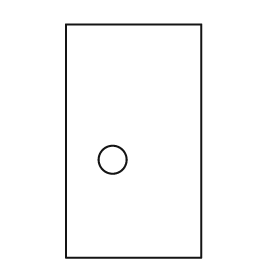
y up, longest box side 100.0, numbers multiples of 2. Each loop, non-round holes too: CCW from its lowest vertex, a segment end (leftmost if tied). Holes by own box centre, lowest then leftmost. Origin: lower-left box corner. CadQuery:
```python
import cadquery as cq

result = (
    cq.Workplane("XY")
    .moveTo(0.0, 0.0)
    .lineTo(58.0, 0.0)
    .lineTo(58.0, 100.0)
    .lineTo(0.0, 100.0)
    .close()
    .moveTo(20.0, 42.0)
    .circle(6.0)
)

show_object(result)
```